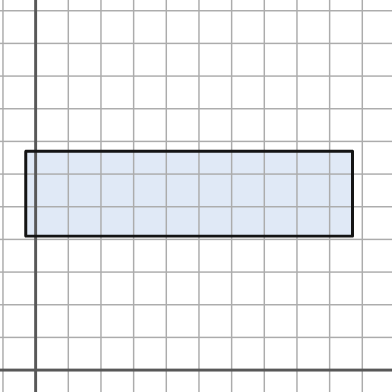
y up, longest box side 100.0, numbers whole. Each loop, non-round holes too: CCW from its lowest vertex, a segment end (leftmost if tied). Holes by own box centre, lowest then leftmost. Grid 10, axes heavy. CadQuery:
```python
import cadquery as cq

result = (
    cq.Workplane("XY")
    .moveTo(-3.0, 41.0)
    .lineTo(97.0, 41.0)
    .lineTo(97.0, 67.0)
    .lineTo(-3.0, 67.0)
    .close()
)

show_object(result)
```